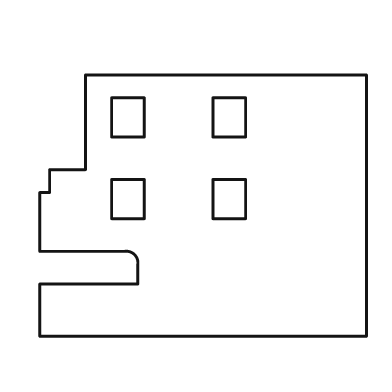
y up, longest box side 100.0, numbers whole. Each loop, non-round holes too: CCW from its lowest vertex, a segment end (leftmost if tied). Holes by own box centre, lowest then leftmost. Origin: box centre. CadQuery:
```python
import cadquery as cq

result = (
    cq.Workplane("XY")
    .moveTo(-50.0, -40.0)
    .lineTo(50.0, -40.0)
    .lineTo(50.0, 40.0)
    .lineTo(-36.0, 40.0)
    .lineTo(-36.0, 11.0)
    .lineTo(-47.0, 11.0)
    .lineTo(-47.0, 4.0)
    .lineTo(-50.0, 4.0)
    .lineTo(-50.0, -14.0)
    .lineTo(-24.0, -14.0)
    .threePointArc((-21.0, -15.0), (-20.0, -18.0))
    .lineTo(-20.0, -24.0)
    .lineTo(-50.0, -24.0)
    .close()
    .moveTo(-28.0, -4.0)
    .lineTo(-18.0, -4.0)
    .lineTo(-18.0, 8.0)
    .lineTo(-28.0, 8.0)
    .close()
    .moveTo(3.0, -4.0)
    .lineTo(13.0, -4.0)
    .lineTo(13.0, 8.0)
    .lineTo(3.0, 8.0)
    .close()
    .moveTo(-28.0, 21.0)
    .lineTo(-18.0, 21.0)
    .lineTo(-18.0, 33.0)
    .lineTo(-28.0, 33.0)
    .close()
    .moveTo(3.0, 21.0)
    .lineTo(13.0, 21.0)
    .lineTo(13.0, 33.0)
    .lineTo(3.0, 33.0)
    .close()
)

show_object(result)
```